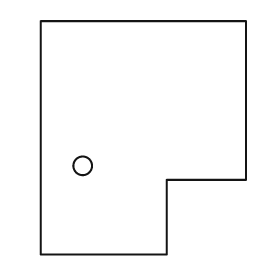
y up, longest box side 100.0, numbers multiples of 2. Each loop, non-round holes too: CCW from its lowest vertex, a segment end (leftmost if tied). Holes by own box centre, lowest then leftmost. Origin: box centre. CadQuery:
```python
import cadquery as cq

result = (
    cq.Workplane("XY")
    .moveTo(-44.0, -50.0)
    .lineTo(10.0, -50.0)
    .lineTo(10.0, -18.0)
    .lineTo(44.0, -18.0)
    .lineTo(44.0, 50.0)
    .lineTo(-44.0, 50.0)
    .close()
    .moveTo(-26.0, -12.0)
    .circle(4.0)
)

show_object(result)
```